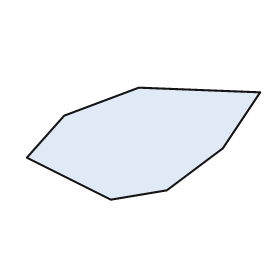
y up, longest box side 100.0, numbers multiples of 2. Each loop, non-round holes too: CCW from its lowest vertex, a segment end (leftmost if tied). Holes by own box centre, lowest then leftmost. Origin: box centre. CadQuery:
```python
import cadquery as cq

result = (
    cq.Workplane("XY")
    .moveTo(-14.0, -24.0)
    .lineTo(10.0, -20.0)
    .lineTo(34.0, -2.0)
    .lineTo(50.0, 22.0)
    .lineTo(-2.0, 24.0)
    .lineTo(-34.0, 12.0)
    .lineTo(-50.0, -6.0)
    .close()
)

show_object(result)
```